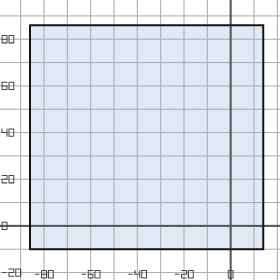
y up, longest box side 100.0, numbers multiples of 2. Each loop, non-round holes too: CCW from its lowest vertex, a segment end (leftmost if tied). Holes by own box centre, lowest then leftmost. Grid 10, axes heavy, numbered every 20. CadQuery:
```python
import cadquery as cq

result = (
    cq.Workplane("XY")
    .moveTo(-86.0, -10.0)
    .lineTo(14.0, -10.0)
    .lineTo(14.0, 86.0)
    .lineTo(-86.0, 86.0)
    .close()
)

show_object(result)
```